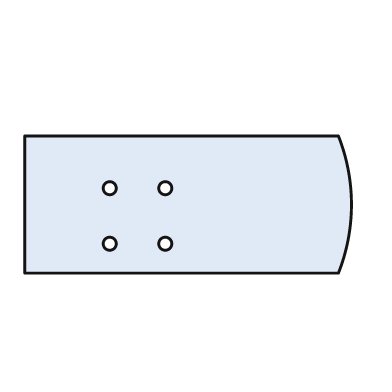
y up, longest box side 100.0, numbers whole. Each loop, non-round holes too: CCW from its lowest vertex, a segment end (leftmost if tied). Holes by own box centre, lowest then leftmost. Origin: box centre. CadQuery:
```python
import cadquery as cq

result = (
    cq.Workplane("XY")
    .moveTo(-50.0, -21.0)
    .lineTo(46.0, -21.0)
    .threePointArc((50.0, 0.0), (46.0, 21.0))
    .lineTo(-50.0, 21.0)
    .close()
    .moveTo(-24.0, -12.0)
    .circle(2.0)
    .moveTo(-7.0, -12.0)
    .circle(2.0)
    .moveTo(-24.0, 5.0)
    .circle(2.0)
    .moveTo(-7.0, 5.0)
    .circle(2.0)
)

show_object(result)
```